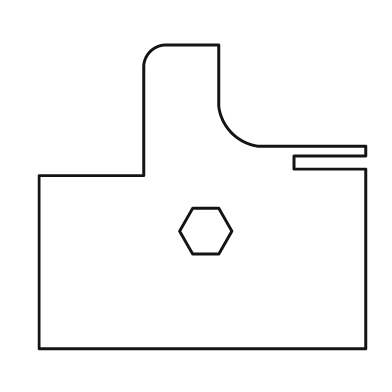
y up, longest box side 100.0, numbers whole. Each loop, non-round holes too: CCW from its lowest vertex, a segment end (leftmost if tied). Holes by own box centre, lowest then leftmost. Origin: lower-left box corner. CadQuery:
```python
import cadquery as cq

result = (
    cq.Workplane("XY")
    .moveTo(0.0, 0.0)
    .lineTo(100.0, 0.0)
    .lineTo(100.0, 55.0)
    .lineTo(78.0, 55.0)
    .lineTo(78.0, 59.0)
    .lineTo(100.0, 59.0)
    .lineTo(100.0, 62.0)
    .lineTo(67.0, 62.0)
    .threePointArc((59.0, 66.0), (55.0, 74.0))
    .lineTo(55.0, 93.0)
    .lineTo(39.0, 93.0)
    .threePointArc((34.0, 91.0), (32.0, 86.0))
    .lineTo(32.0, 53.0)
    .lineTo(0.0, 53.0)
    .close()
    .moveTo(47.0, 29.0)
    .lineTo(55.0, 29.0)
    .lineTo(59.0, 36.0)
    .lineTo(55.0, 43.0)
    .lineTo(47.0, 43.0)
    .lineTo(43.0, 36.0)
    .close()
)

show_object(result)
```